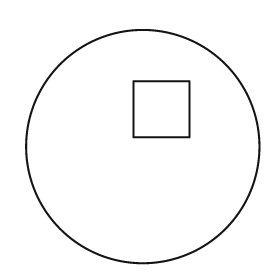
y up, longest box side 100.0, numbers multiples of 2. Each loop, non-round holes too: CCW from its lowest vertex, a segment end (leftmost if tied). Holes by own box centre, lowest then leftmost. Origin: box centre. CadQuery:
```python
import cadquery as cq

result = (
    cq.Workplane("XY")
    .moveTo(0.0, 0.0)
    .circle(50.0)
    .moveTo(-4.0, 4.0)
    .lineTo(20.0, 4.0)
    .lineTo(20.0, 28.0)
    .lineTo(-4.0, 28.0)
    .close()
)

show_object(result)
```